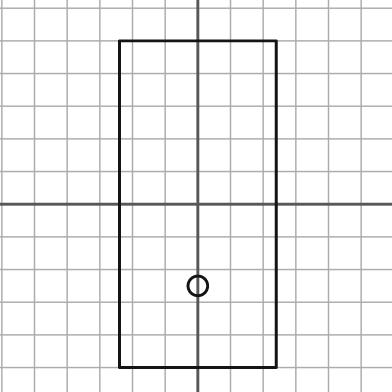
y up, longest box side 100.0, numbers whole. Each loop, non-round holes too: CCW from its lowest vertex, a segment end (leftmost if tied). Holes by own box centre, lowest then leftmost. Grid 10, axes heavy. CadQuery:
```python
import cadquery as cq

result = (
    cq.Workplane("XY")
    .moveTo(-24.0, -50.0)
    .lineTo(24.0, -50.0)
    .lineTo(24.0, 50.0)
    .lineTo(-24.0, 50.0)
    .close()
    .moveTo(0.0, -25.0)
    .circle(3.0)
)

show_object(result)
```